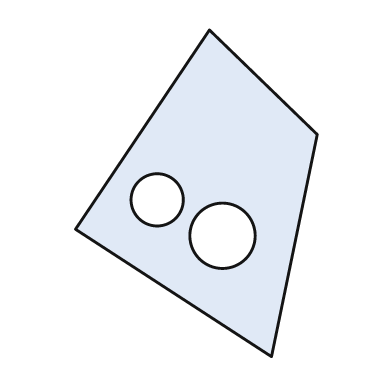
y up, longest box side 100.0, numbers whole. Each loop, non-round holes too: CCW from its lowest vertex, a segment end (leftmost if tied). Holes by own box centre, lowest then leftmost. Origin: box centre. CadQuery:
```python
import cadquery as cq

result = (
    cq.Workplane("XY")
    .moveTo(23.0, -50.0)
    .lineTo(37.0, 18.0)
    .lineTo(4.0, 50.0)
    .lineTo(-37.0, -11.0)
    .close()
    .moveTo(8.0, -13.0)
    .circle(10.0)
    .moveTo(-12.0, -2.0)
    .circle(8.0)
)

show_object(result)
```